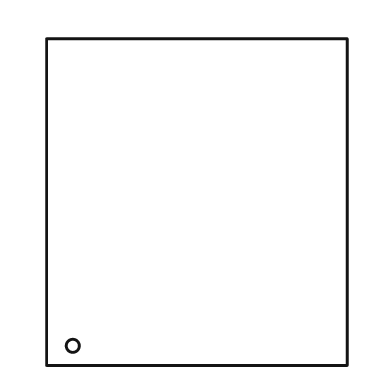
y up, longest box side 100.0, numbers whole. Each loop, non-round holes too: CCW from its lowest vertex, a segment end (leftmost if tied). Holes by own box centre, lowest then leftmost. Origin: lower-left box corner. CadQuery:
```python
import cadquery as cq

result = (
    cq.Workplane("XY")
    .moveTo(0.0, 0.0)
    .lineTo(92.0, 0.0)
    .lineTo(92.0, 100.0)
    .lineTo(0.0, 100.0)
    .close()
    .moveTo(8.0, 6.0)
    .circle(2.0)
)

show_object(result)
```